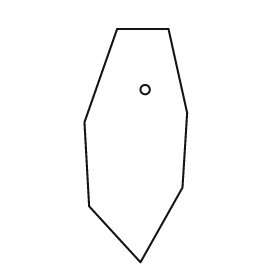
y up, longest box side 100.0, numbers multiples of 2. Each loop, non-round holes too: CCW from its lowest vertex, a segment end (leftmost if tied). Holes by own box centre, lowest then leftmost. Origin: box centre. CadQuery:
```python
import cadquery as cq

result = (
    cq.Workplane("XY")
    .moveTo(2.0, -50.0)
    .lineTo(20.0, -18.0)
    .lineTo(22.0, 14.0)
    .lineTo(14.0, 50.0)
    .lineTo(-8.0, 50.0)
    .lineTo(-22.0, 10.0)
    .lineTo(-20.0, -26.0)
    .close()
    .moveTo(4.0, 24.0)
    .circle(2.0)
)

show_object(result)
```